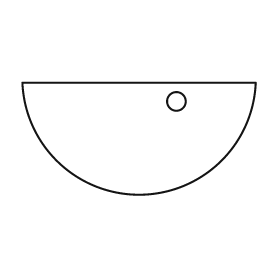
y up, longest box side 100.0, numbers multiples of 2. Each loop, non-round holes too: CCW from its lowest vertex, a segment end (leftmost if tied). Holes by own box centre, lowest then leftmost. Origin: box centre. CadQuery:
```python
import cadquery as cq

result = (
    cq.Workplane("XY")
    .moveTo(-50.0, 24.0)
    .threePointArc((0.0, -24.0), (50.0, 24.0))
    .close()
    .moveTo(16.0, 16.0)
    .circle(4.0)
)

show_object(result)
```